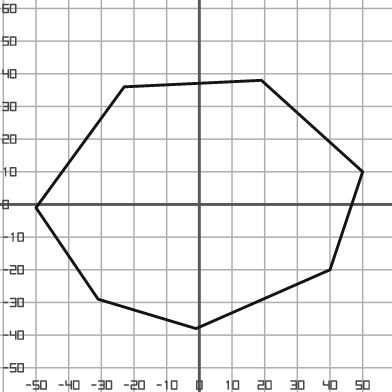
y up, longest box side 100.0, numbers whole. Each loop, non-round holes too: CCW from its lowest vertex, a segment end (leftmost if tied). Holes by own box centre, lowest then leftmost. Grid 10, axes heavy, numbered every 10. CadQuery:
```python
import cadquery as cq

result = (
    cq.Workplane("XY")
    .moveTo(-1.0, -38.0)
    .lineTo(40.0, -20.0)
    .lineTo(50.0, 10.0)
    .lineTo(19.0, 38.0)
    .lineTo(-23.0, 36.0)
    .lineTo(-50.0, -1.0)
    .lineTo(-31.0, -29.0)
    .close()
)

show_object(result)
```